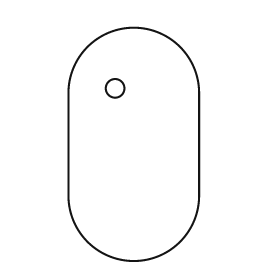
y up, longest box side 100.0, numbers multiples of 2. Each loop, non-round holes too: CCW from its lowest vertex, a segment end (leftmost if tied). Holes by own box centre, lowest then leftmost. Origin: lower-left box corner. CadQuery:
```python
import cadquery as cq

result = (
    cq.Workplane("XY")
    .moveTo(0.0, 28.0)
    .threePointArc((28.0, 0.0), (56.0, 28.0))
    .lineTo(56.0, 72.0)
    .threePointArc((28.0, 100.0), (0.0, 72.0))
    .close()
    .moveTo(20.0, 74.0)
    .circle(4.0)
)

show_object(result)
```